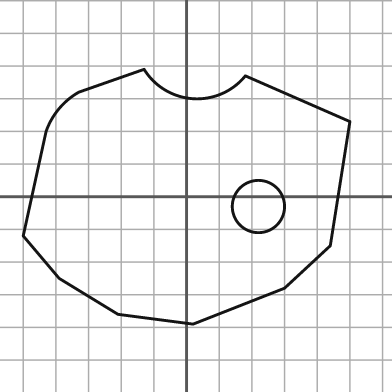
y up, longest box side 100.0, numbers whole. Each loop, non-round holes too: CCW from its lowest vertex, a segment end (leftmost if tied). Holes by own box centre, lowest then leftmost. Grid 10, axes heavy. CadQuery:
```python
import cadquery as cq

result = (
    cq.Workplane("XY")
    .moveTo(2.0, -39.0)
    .lineTo(30.0, -28.0)
    .lineTo(44.0, -15.0)
    .lineTo(50.0, 23.0)
    .lineTo(18.0, 37.0)
    .threePointArc((2.0, 30.0), (-13.0, 39.0))
    .lineTo(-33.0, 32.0)
    .threePointArc((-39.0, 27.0), (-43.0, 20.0))
    .lineTo(-50.0, -12.0)
    .lineTo(-39.0, -25.0)
    .lineTo(-21.0, -36.0)
    .close()
    .moveTo(22.0, -3.0)
    .circle(8.0)
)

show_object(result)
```